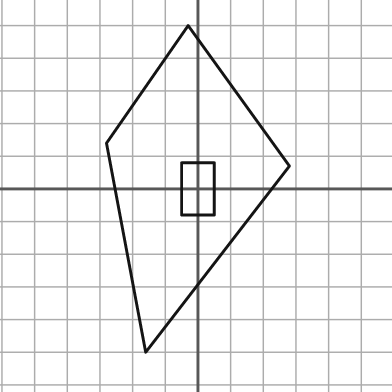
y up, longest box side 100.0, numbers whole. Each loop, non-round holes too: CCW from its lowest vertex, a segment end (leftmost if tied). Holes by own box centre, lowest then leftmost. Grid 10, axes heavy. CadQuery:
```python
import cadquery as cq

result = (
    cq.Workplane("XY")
    .moveTo(-16.0, -50.0)
    .lineTo(28.0, 7.0)
    .lineTo(-3.0, 50.0)
    .lineTo(-28.0, 14.0)
    .close()
    .moveTo(-5.0, -8.0)
    .lineTo(5.0, -8.0)
    .lineTo(5.0, 8.0)
    .lineTo(-5.0, 8.0)
    .close()
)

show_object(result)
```